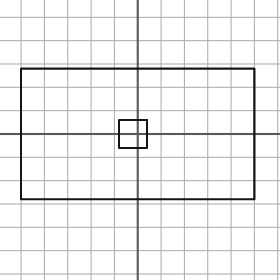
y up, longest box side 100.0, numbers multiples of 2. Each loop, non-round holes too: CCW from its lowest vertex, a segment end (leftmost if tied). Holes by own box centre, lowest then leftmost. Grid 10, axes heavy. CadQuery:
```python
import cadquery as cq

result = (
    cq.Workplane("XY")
    .moveTo(-50.0, -28.0)
    .lineTo(50.0, -28.0)
    .lineTo(50.0, 28.0)
    .lineTo(-50.0, 28.0)
    .close()
    .moveTo(-8.0, -6.0)
    .lineTo(4.0, -6.0)
    .lineTo(4.0, 6.0)
    .lineTo(-8.0, 6.0)
    .close()
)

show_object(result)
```